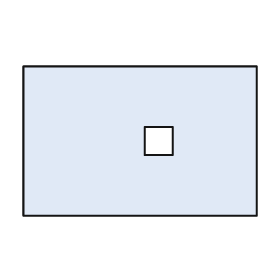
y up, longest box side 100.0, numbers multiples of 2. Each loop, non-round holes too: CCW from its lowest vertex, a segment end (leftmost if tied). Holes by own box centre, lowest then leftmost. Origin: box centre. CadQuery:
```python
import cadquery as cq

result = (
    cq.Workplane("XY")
    .moveTo(-50.0, -32.0)
    .lineTo(50.0, -32.0)
    .lineTo(50.0, 32.0)
    .lineTo(-50.0, 32.0)
    .close()
    .moveTo(2.0, -6.0)
    .lineTo(14.0, -6.0)
    .lineTo(14.0, 6.0)
    .lineTo(2.0, 6.0)
    .close()
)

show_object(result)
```